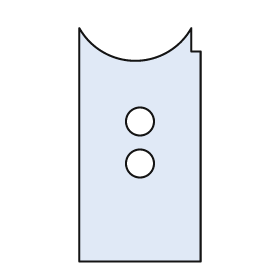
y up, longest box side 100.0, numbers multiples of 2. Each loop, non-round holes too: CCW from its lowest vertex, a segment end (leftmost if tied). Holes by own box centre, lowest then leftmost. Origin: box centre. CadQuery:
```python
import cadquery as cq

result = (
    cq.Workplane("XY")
    .moveTo(-26.0, -50.0)
    .lineTo(26.0, -50.0)
    .lineTo(26.0, 40.0)
    .lineTo(22.0, 40.0)
    .lineTo(22.0, 50.0)
    .threePointArc((-2.0, 36.0), (-26.0, 50.0))
    .close()
    .moveTo(0.0, -8.0)
    .circle(6.0)
    .moveTo(0.0, 10.0)
    .circle(6.0)
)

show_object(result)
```